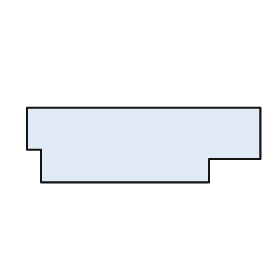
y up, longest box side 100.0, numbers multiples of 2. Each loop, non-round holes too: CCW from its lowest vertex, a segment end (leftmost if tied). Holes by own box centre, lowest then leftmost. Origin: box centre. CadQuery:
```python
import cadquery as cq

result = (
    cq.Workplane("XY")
    .moveTo(-44.0, -16.0)
    .lineTo(28.0, -16.0)
    .lineTo(28.0, -6.0)
    .lineTo(50.0, -6.0)
    .lineTo(50.0, 16.0)
    .lineTo(-50.0, 16.0)
    .lineTo(-50.0, -2.0)
    .lineTo(-44.0, -2.0)
    .close()
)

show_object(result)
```